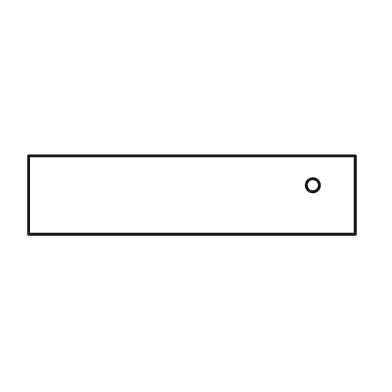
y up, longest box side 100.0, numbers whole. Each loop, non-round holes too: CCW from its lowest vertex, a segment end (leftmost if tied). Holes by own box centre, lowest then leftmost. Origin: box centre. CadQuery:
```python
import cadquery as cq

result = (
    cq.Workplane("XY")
    .moveTo(-50.0, -12.0)
    .lineTo(50.0, -12.0)
    .lineTo(50.0, 12.0)
    .lineTo(-50.0, 12.0)
    .close()
    .moveTo(37.0, 3.0)
    .circle(2.0)
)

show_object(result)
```